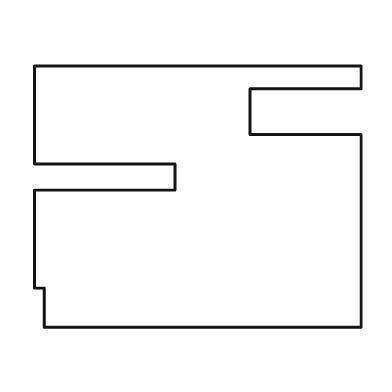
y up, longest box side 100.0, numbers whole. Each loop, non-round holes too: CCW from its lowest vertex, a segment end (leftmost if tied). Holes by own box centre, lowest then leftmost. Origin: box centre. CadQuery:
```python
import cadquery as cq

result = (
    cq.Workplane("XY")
    .moveTo(-47.0, -40.0)
    .lineTo(50.0, -40.0)
    .lineTo(50.0, 19.0)
    .lineTo(16.0, 19.0)
    .lineTo(16.0, 33.0)
    .lineTo(50.0, 33.0)
    .lineTo(50.0, 40.0)
    .lineTo(-50.0, 40.0)
    .lineTo(-50.0, 10.0)
    .lineTo(-7.0, 10.0)
    .lineTo(-7.0, 2.0)
    .lineTo(-50.0, 2.0)
    .lineTo(-50.0, -28.0)
    .lineTo(-47.0, -28.0)
    .close()
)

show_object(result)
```